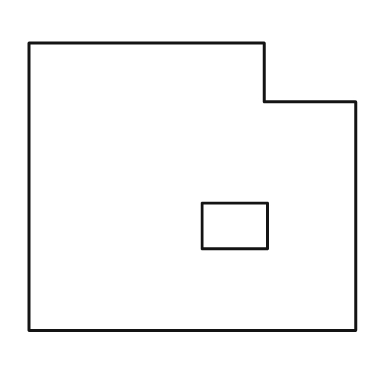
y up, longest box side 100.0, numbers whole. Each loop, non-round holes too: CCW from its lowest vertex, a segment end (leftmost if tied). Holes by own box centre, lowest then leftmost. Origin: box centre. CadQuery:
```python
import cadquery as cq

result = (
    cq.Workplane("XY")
    .moveTo(-50.0, -44.0)
    .lineTo(50.0, -44.0)
    .lineTo(50.0, 26.0)
    .lineTo(22.0, 26.0)
    .lineTo(22.0, 44.0)
    .lineTo(-50.0, 44.0)
    .close()
    .moveTo(3.0, -19.0)
    .lineTo(23.0, -19.0)
    .lineTo(23.0, -5.0)
    .lineTo(3.0, -5.0)
    .close()
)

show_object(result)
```